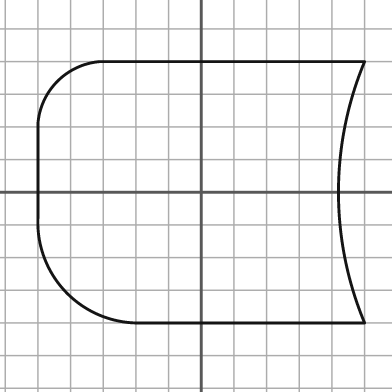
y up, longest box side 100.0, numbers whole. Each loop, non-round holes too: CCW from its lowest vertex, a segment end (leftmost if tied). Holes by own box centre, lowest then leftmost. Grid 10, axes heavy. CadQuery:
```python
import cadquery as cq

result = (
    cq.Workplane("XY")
    .moveTo(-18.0, -40.0)
    .lineTo(50.0, -40.0)
    .threePointArc((42.0, 0.0), (50.0, 40.0))
    .lineTo(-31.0, 40.0)
    .threePointArc((-44.0, 34.0), (-50.0, 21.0))
    .lineTo(-50.0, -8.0)
    .threePointArc((-41.0, -31.0), (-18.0, -40.0))
    .close()
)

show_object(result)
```